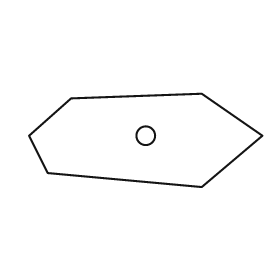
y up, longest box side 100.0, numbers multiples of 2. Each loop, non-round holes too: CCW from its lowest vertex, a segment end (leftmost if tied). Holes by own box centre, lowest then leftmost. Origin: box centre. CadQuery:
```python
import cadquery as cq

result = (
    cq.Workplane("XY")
    .moveTo(24.0, -20.0)
    .lineTo(50.0, 2.0)
    .lineTo(24.0, 20.0)
    .lineTo(-32.0, 18.0)
    .lineTo(-50.0, 2.0)
    .lineTo(-42.0, -14.0)
    .close()
    .moveTo(0.0, 2.0)
    .circle(4.0)
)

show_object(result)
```